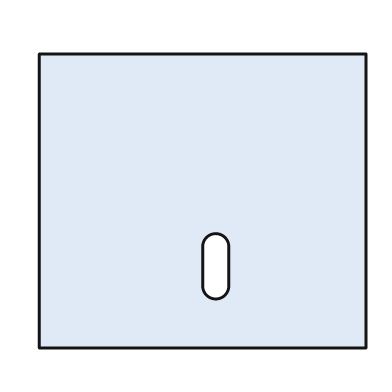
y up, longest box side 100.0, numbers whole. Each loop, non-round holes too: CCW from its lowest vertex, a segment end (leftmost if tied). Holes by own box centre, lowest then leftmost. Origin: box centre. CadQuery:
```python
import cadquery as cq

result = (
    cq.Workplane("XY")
    .moveTo(-50.0, -45.0)
    .lineTo(50.0, -45.0)
    .lineTo(50.0, 45.0)
    .lineTo(-50.0, 45.0)
    .close()
    .moveTo(0.0, -26.0)
    .threePointArc((4.0, -30.0), (8.0, -26.0))
    .lineTo(8.0, -14.0)
    .threePointArc((4.0, -10.0), (0.0, -14.0))
    .close()
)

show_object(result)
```